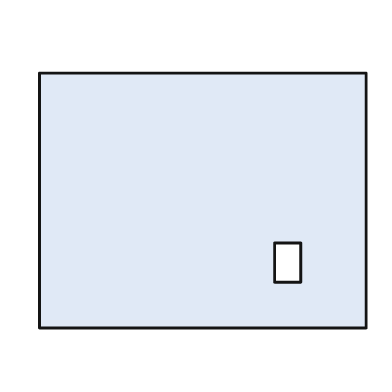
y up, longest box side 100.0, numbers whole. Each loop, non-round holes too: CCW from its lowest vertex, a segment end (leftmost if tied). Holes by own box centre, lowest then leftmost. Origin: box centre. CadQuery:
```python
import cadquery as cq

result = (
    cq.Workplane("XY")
    .moveTo(-50.0, -39.0)
    .lineTo(50.0, -39.0)
    .lineTo(50.0, 39.0)
    .lineTo(-50.0, 39.0)
    .close()
    .moveTo(22.0, -25.0)
    .lineTo(30.0, -25.0)
    .lineTo(30.0, -13.0)
    .lineTo(22.0, -13.0)
    .close()
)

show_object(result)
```